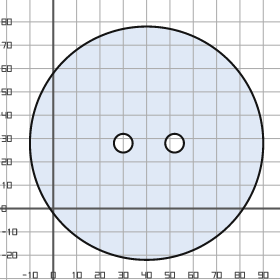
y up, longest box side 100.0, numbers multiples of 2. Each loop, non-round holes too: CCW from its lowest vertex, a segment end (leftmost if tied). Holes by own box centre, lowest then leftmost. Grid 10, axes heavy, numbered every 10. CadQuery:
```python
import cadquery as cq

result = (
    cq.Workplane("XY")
    .moveTo(40.0, 28.0)
    .circle(50.0)
    .moveTo(30.0, 28.0)
    .circle(4.0)
    .moveTo(52.0, 28.0)
    .circle(4.0)
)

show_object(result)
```